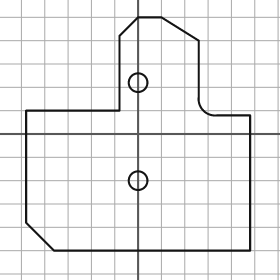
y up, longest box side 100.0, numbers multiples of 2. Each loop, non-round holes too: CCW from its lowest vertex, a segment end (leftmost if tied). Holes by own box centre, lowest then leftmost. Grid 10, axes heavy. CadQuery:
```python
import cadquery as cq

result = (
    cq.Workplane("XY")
    .moveTo(-36.0, -50.0)
    .lineTo(48.0, -50.0)
    .lineTo(48.0, 8.0)
    .lineTo(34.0, 8.0)
    .threePointArc((28.0, 10.0), (26.0, 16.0))
    .lineTo(26.0, 40.0)
    .lineTo(10.0, 50.0)
    .lineTo(0.0, 50.0)
    .lineTo(-8.0, 42.0)
    .lineTo(-8.0, 10.0)
    .lineTo(-48.0, 10.0)
    .lineTo(-48.0, -38.0)
    .close()
    .moveTo(0.0, -20.0)
    .circle(4.0)
    .moveTo(0.0, 22.0)
    .circle(4.0)
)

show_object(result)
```